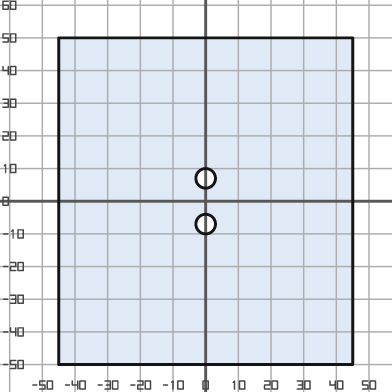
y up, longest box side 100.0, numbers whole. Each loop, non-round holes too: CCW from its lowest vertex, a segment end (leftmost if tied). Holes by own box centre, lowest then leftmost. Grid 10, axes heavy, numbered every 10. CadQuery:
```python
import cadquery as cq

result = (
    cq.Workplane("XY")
    .moveTo(-45.0, -50.0)
    .lineTo(45.0, -50.0)
    .lineTo(45.0, 50.0)
    .lineTo(-45.0, 50.0)
    .close()
    .moveTo(0.0, -7.0)
    .circle(3.0)
    .moveTo(0.0, 7.0)
    .circle(3.0)
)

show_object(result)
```